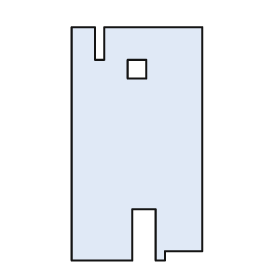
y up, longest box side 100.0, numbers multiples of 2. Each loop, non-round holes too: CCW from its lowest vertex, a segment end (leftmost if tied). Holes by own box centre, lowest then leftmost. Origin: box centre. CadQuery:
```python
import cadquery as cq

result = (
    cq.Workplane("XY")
    .moveTo(-28.0, -50.0)
    .lineTo(-2.0, -50.0)
    .lineTo(-2.0, -28.0)
    .lineTo(8.0, -28.0)
    .lineTo(8.0, -50.0)
    .lineTo(12.0, -50.0)
    .lineTo(12.0, -46.0)
    .lineTo(28.0, -46.0)
    .lineTo(28.0, 50.0)
    .lineTo(-14.0, 50.0)
    .lineTo(-14.0, 36.0)
    .lineTo(-18.0, 36.0)
    .lineTo(-18.0, 50.0)
    .lineTo(-28.0, 50.0)
    .close()
    .moveTo(-4.0, 28.0)
    .lineTo(4.0, 28.0)
    .lineTo(4.0, 36.0)
    .lineTo(-4.0, 36.0)
    .close()
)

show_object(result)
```